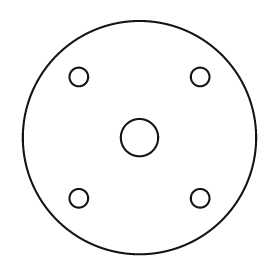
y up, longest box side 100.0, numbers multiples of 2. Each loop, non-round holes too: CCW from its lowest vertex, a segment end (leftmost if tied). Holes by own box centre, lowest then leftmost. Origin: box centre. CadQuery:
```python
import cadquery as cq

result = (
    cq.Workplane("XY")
    .moveTo(0.0, 0.0)
    .circle(50.0)
    .moveTo(-26.0, -26.0)
    .circle(4.0)
    .moveTo(26.0, -26.0)
    .circle(4.0)
    .moveTo(0.0, 0.0)
    .circle(8.0)
    .moveTo(-26.0, 26.0)
    .circle(4.0)
    .moveTo(26.0, 26.0)
    .circle(4.0)
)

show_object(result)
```